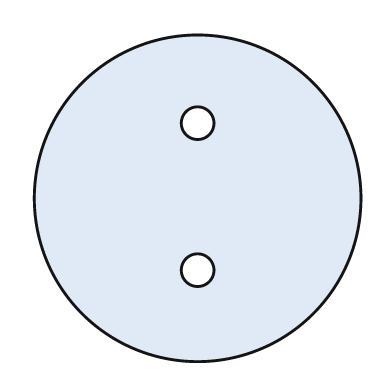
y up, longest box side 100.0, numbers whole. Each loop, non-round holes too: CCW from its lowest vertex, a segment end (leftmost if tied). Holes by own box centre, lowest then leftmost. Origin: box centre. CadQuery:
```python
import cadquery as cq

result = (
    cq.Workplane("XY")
    .moveTo(0.0, 0.0)
    .circle(50.0)
    .moveTo(0.0, -22.0)
    .circle(5.0)
    .moveTo(0.0, 23.0)
    .circle(5.0)
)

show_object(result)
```